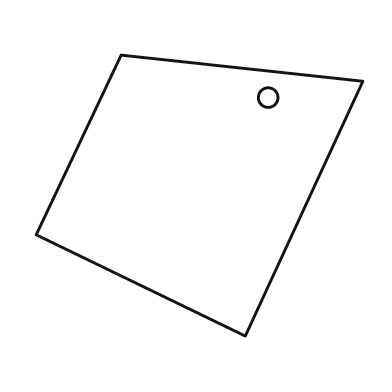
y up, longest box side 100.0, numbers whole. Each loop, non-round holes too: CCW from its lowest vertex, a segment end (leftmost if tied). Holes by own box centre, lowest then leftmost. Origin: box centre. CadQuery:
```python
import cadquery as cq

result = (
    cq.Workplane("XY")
    .moveTo(14.0, -43.0)
    .lineTo(50.0, 35.0)
    .lineTo(-24.0, 43.0)
    .lineTo(-50.0, -12.0)
    .close()
    .moveTo(21.0, 30.0)
    .circle(3.0)
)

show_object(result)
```